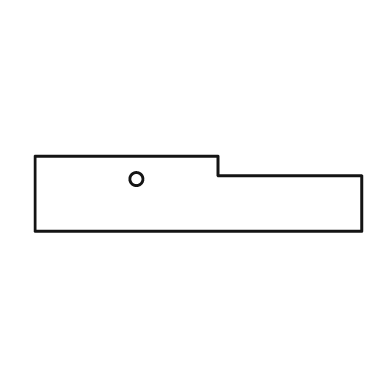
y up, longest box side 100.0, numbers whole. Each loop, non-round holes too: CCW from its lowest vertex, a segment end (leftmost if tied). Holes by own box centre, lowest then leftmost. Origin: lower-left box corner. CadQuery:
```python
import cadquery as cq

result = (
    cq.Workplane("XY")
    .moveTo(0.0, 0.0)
    .lineTo(100.0, 0.0)
    .lineTo(100.0, 17.0)
    .lineTo(56.0, 17.0)
    .lineTo(56.0, 23.0)
    .lineTo(0.0, 23.0)
    .close()
    .moveTo(31.0, 16.0)
    .circle(2.0)
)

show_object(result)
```